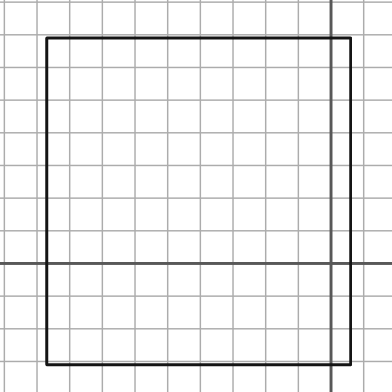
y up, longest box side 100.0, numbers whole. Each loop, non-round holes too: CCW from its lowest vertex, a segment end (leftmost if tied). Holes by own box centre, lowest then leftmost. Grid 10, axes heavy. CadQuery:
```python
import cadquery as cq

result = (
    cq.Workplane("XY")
    .moveTo(-87.0, -31.0)
    .lineTo(6.0, -31.0)
    .lineTo(6.0, 69.0)
    .lineTo(-87.0, 69.0)
    .close()
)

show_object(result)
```